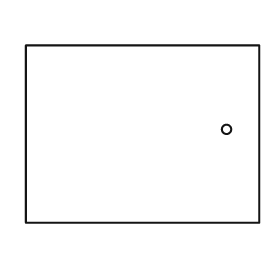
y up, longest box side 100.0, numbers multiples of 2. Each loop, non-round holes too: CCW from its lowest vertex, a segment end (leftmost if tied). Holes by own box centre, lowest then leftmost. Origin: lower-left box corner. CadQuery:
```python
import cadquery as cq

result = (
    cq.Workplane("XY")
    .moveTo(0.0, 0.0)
    .lineTo(100.0, 0.0)
    .lineTo(100.0, 76.0)
    .lineTo(0.0, 76.0)
    .close()
    .moveTo(86.0, 40.0)
    .circle(2.0)
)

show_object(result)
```